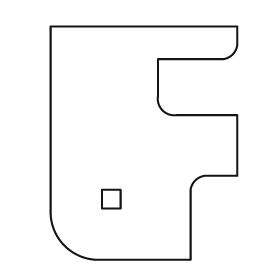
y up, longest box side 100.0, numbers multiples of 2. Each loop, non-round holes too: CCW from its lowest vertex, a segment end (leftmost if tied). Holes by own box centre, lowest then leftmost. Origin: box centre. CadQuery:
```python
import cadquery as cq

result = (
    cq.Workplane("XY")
    .moveTo(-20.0, -50.0)
    .lineTo(20.0, -50.0)
    .lineTo(20.0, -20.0)
    .threePointArc((22.0, -16.0), (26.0, -14.0))
    .lineTo(40.0, -14.0)
    .lineTo(40.0, 12.0)
    .lineTo(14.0, 12.0)
    .threePointArc((8.0, 14.0), (6.0, 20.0))
    .lineTo(6.0, 36.0)
    .lineTo(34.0, 36.0)
    .threePointArc((38.0, 38.0), (40.0, 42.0))
    .lineTo(40.0, 50.0)
    .lineTo(-40.0, 50.0)
    .lineTo(-40.0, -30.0)
    .threePointArc((-34.0, -44.0), (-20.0, -50.0))
    .close()
    .moveTo(-18.0, -28.0)
    .lineTo(-10.0, -28.0)
    .lineTo(-10.0, -20.0)
    .lineTo(-18.0, -20.0)
    .close()
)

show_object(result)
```